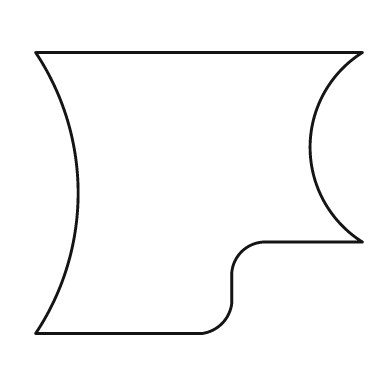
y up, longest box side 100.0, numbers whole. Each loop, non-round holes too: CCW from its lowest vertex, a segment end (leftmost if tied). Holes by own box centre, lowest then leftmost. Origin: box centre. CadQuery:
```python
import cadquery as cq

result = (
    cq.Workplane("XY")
    .moveTo(-50.0, -43.0)
    .lineTo(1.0, -43.0)
    .threePointArc((7.0, -40.0), (10.0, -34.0))
    .lineTo(10.0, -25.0)
    .threePointArc((13.0, -18.0), (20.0, -15.0))
    .lineTo(50.0, -15.0)
    .threePointArc((34.0, 14.0), (50.0, 43.0))
    .lineTo(-50.0, 43.0)
    .threePointArc((-37.0, 0.0), (-50.0, -43.0))
    .close()
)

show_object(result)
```